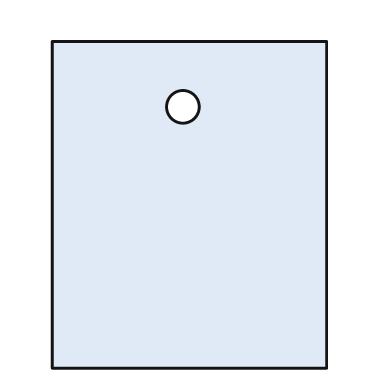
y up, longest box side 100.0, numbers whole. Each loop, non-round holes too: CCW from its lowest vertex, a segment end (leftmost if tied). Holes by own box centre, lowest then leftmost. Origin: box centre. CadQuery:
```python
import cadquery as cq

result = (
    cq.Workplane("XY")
    .moveTo(-42.0, -50.0)
    .lineTo(42.0, -50.0)
    .lineTo(42.0, 50.0)
    .lineTo(-42.0, 50.0)
    .close()
    .moveTo(-2.0, 30.0)
    .circle(5.0)
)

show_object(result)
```